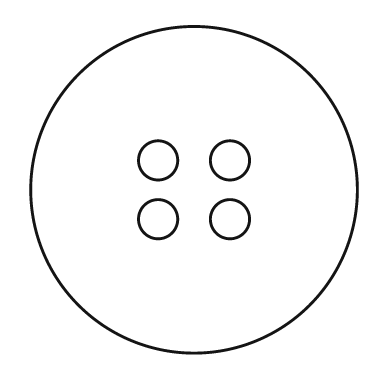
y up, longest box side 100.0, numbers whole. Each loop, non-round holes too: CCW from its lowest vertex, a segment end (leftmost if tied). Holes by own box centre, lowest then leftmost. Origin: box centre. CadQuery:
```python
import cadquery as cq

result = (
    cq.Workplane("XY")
    .moveTo(0.0, 0.0)
    .circle(50.0)
    .moveTo(-11.0, -9.0)
    .circle(6.0)
    .moveTo(11.0, -9.0)
    .circle(6.0)
    .moveTo(-11.0, 9.0)
    .circle(6.0)
    .moveTo(11.0, 9.0)
    .circle(6.0)
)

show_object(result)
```